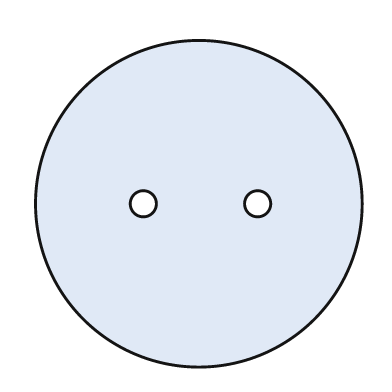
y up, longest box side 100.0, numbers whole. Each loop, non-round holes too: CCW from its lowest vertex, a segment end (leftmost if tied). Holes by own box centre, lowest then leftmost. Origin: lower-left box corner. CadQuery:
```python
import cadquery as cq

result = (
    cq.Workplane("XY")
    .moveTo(50.0, 50.0)
    .circle(50.0)
    .moveTo(33.0, 50.0)
    .circle(4.0)
    .moveTo(68.0, 50.0)
    .circle(4.0)
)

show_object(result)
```